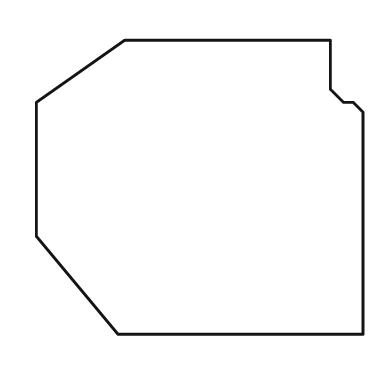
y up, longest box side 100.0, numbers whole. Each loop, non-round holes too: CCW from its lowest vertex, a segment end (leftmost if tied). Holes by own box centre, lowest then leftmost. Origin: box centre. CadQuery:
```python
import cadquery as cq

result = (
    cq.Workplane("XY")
    .moveTo(-25.0, -45.0)
    .lineTo(50.0, -45.0)
    .lineTo(50.0, 23.0)
    .lineTo(47.0, 26.0)
    .lineTo(44.0, 26.0)
    .lineTo(40.0, 30.0)
    .lineTo(40.0, 45.0)
    .lineTo(-23.0, 45.0)
    .lineTo(-50.0, 26.0)
    .lineTo(-50.0, -15.0)
    .close()
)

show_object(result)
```